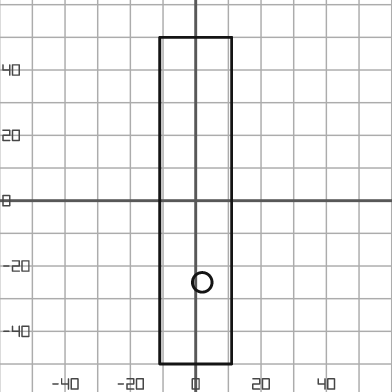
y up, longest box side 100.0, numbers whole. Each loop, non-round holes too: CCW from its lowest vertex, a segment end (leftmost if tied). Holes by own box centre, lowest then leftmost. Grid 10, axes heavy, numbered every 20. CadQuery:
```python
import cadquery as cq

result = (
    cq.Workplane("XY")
    .moveTo(-11.0, -50.0)
    .lineTo(11.0, -50.0)
    .lineTo(11.0, 50.0)
    .lineTo(-11.0, 50.0)
    .close()
    .moveTo(2.0, -25.0)
    .circle(3.0)
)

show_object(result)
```